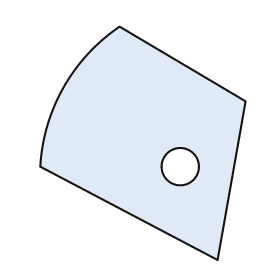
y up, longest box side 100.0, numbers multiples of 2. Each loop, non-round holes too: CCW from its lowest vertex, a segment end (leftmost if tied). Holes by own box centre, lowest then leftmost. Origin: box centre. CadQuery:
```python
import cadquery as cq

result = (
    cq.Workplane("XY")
    .moveTo(32.0, -50.0)
    .lineTo(44.0, 18.0)
    .lineTo(-10.0, 50.0)
    .threePointArc((-34.0, 24.0), (-44.0, -10.0))
    .close()
    .moveTo(16.0, -10.0)
    .circle(8.0)
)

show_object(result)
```